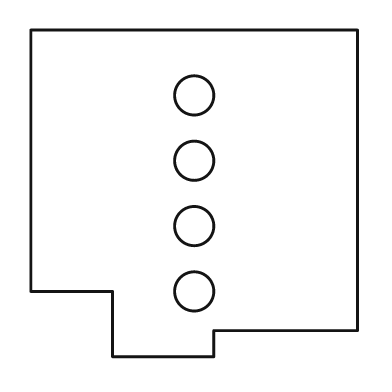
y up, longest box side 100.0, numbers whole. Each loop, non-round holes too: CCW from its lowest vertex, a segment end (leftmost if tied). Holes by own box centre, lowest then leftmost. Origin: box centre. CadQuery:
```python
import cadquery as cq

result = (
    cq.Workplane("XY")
    .moveTo(-25.0, -50.0)
    .lineTo(6.0, -50.0)
    .lineTo(6.0, -42.0)
    .lineTo(50.0, -42.0)
    .lineTo(50.0, 50.0)
    .lineTo(-50.0, 50.0)
    .lineTo(-50.0, -30.0)
    .lineTo(-25.0, -30.0)
    .close()
    .moveTo(0.0, -30.0)
    .circle(6.0)
    .moveTo(0.0, -10.0)
    .circle(6.0)
    .moveTo(0.0, 10.0)
    .circle(6.0)
    .moveTo(0.0, 30.0)
    .circle(6.0)
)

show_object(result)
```